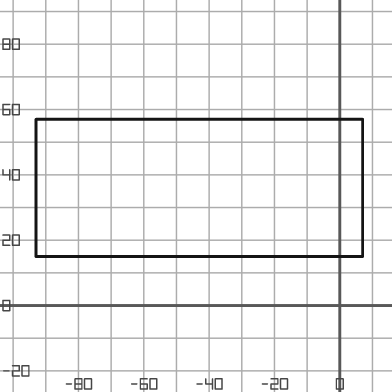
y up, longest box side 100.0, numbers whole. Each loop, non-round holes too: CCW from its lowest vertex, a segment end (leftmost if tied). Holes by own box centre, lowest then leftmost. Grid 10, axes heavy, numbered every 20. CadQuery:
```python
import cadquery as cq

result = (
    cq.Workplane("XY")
    .moveTo(-93.0, 15.0)
    .lineTo(7.0, 15.0)
    .lineTo(7.0, 57.0)
    .lineTo(-93.0, 57.0)
    .close()
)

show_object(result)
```